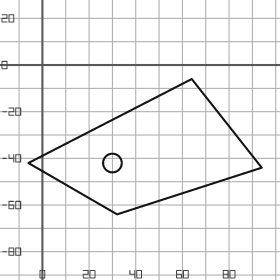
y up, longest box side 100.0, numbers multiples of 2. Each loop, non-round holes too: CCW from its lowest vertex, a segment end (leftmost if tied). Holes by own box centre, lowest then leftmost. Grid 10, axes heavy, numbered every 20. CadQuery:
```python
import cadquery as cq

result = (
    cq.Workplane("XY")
    .moveTo(32.0, -64.0)
    .lineTo(94.0, -44.0)
    .lineTo(64.0, -6.0)
    .lineTo(-6.0, -42.0)
    .close()
    .moveTo(30.0, -42.0)
    .circle(4.0)
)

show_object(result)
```